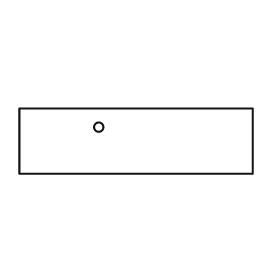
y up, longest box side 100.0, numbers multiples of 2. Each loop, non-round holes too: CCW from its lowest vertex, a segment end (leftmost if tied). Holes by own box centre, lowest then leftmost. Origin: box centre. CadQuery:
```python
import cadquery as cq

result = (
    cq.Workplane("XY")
    .moveTo(-50.0, -14.0)
    .lineTo(50.0, -14.0)
    .lineTo(50.0, 14.0)
    .lineTo(-50.0, 14.0)
    .close()
    .moveTo(-16.0, 6.0)
    .circle(2.0)
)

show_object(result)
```